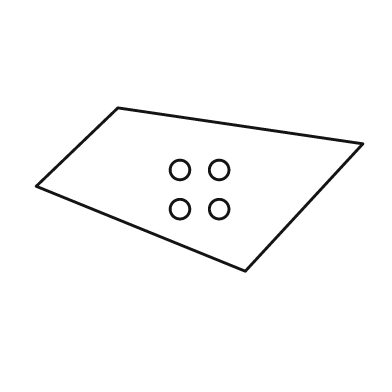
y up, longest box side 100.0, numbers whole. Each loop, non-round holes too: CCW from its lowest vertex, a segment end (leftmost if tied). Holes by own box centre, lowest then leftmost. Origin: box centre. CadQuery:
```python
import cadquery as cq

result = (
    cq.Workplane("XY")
    .moveTo(14.0, -25.0)
    .lineTo(50.0, 14.0)
    .lineTo(-25.0, 25.0)
    .lineTo(-50.0, 1.0)
    .close()
    .moveTo(-6.0, -6.0)
    .circle(3.0)
    .moveTo(6.0, -6.0)
    .circle(3.0)
    .moveTo(-6.0, 6.0)
    .circle(3.0)
    .moveTo(6.0, 6.0)
    .circle(3.0)
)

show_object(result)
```